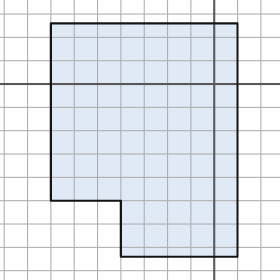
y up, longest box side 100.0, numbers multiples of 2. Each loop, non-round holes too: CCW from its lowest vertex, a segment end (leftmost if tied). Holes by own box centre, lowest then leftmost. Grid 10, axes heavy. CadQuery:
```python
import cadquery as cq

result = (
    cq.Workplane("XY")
    .moveTo(-40.0, -74.0)
    .lineTo(10.0, -74.0)
    .lineTo(10.0, 26.0)
    .lineTo(-70.0, 26.0)
    .lineTo(-70.0, -50.0)
    .lineTo(-40.0, -50.0)
    .close()
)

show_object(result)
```